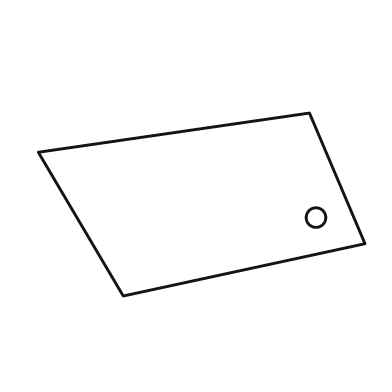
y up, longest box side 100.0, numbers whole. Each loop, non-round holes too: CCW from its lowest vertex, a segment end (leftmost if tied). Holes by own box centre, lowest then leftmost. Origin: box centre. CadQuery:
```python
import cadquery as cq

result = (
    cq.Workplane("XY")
    .moveTo(-24.0, -28.0)
    .lineTo(50.0, -12.0)
    .lineTo(33.0, 28.0)
    .lineTo(-50.0, 16.0)
    .close()
    .moveTo(35.0, -4.0)
    .circle(3.0)
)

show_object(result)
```